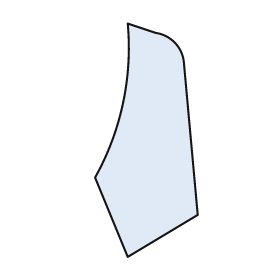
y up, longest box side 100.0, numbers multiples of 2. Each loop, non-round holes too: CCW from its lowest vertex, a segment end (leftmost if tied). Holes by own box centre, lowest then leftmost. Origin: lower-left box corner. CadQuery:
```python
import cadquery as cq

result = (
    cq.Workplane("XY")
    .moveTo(14.0, 0.0)
    .lineTo(44.0, 18.0)
    .lineTo(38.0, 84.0)
    .threePointArc((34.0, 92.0), (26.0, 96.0))
    .lineTo(14.0, 100.0)
    .threePointArc((12.0, 66.0), (0.0, 34.0))
    .close()
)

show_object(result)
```